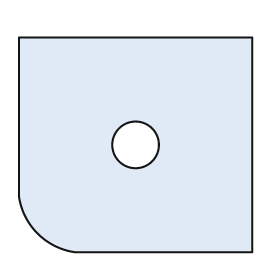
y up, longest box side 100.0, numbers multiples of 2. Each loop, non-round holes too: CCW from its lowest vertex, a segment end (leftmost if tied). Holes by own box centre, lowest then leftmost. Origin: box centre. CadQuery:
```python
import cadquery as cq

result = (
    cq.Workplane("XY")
    .moveTo(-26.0, -46.0)
    .lineTo(50.0, -46.0)
    .lineTo(50.0, 46.0)
    .lineTo(-50.0, 46.0)
    .lineTo(-50.0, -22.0)
    .threePointArc((-42.0, -38.0), (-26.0, -46.0))
    .close()
    .moveTo(0.0, 0.0)
    .circle(10.0)
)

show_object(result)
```